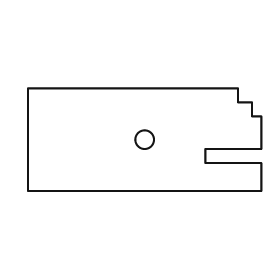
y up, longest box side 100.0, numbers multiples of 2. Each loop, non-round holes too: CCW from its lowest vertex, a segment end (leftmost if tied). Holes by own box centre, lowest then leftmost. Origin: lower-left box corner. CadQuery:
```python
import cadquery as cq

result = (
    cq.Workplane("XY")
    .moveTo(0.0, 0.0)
    .lineTo(100.0, 0.0)
    .lineTo(100.0, 12.0)
    .lineTo(76.0, 12.0)
    .lineTo(76.0, 18.0)
    .lineTo(100.0, 18.0)
    .lineTo(100.0, 32.0)
    .lineTo(96.0, 32.0)
    .lineTo(96.0, 38.0)
    .lineTo(90.0, 38.0)
    .lineTo(90.0, 44.0)
    .lineTo(0.0, 44.0)
    .close()
    .moveTo(50.0, 22.0)
    .circle(4.0)
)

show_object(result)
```